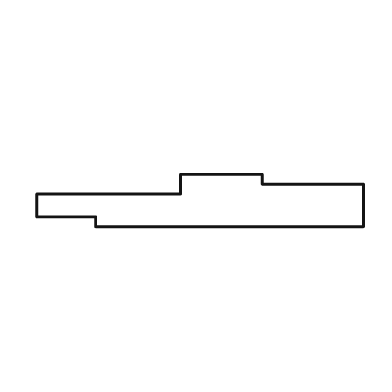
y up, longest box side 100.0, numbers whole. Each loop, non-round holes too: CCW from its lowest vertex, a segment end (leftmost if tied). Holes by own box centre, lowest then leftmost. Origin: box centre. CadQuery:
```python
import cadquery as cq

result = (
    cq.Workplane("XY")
    .moveTo(-32.0, -8.0)
    .lineTo(50.0, -8.0)
    .lineTo(50.0, 5.0)
    .lineTo(19.0, 5.0)
    .lineTo(19.0, 8.0)
    .lineTo(-6.0, 8.0)
    .lineTo(-6.0, 2.0)
    .lineTo(-50.0, 2.0)
    .lineTo(-50.0, -5.0)
    .lineTo(-32.0, -5.0)
    .close()
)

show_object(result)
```